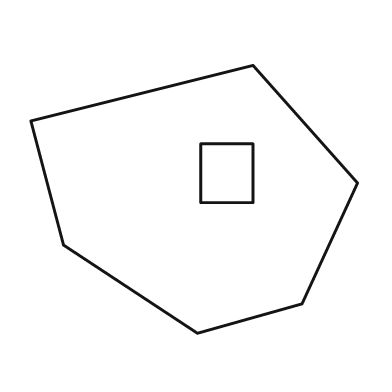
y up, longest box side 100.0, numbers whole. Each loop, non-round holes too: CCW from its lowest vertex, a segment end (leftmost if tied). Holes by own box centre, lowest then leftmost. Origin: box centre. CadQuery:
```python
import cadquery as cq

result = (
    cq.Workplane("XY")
    .moveTo(1.0, -41.0)
    .lineTo(33.0, -32.0)
    .lineTo(50.0, 5.0)
    .lineTo(18.0, 41.0)
    .lineTo(-50.0, 24.0)
    .lineTo(-40.0, -14.0)
    .close()
    .moveTo(2.0, -1.0)
    .lineTo(18.0, -1.0)
    .lineTo(18.0, 17.0)
    .lineTo(2.0, 17.0)
    .close()
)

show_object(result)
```